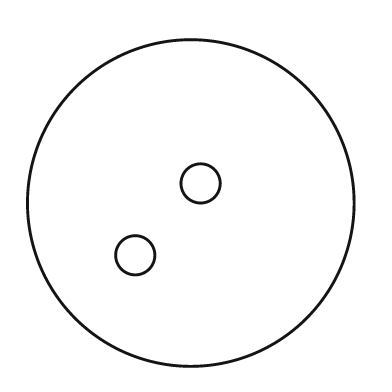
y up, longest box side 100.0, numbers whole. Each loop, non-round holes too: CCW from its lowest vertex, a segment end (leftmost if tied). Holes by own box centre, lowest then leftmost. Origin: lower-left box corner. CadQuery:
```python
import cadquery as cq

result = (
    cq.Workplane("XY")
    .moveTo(50.0, 50.0)
    .circle(50.0)
    .moveTo(33.0, 34.0)
    .circle(6.0)
    .moveTo(53.0, 56.0)
    .circle(6.0)
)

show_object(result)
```